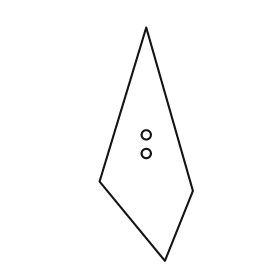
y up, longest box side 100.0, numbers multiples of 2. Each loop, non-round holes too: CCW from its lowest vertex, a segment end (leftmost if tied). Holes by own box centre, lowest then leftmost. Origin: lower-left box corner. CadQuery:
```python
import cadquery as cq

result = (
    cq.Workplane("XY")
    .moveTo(28.0, 0.0)
    .lineTo(40.0, 30.0)
    .lineTo(20.0, 100.0)
    .lineTo(0.0, 34.0)
    .close()
    .moveTo(20.0, 46.0)
    .circle(2.0)
    .moveTo(20.0, 54.0)
    .circle(2.0)
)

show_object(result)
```